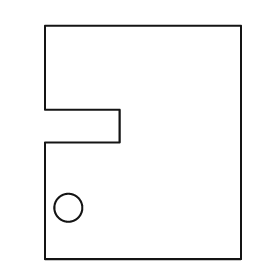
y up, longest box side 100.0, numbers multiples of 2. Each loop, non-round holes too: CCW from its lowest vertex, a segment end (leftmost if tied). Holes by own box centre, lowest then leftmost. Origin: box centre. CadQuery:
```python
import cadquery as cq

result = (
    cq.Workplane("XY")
    .moveTo(-42.0, -50.0)
    .lineTo(42.0, -50.0)
    .lineTo(42.0, 50.0)
    .lineTo(-42.0, 50.0)
    .lineTo(-42.0, 14.0)
    .lineTo(-10.0, 14.0)
    .lineTo(-10.0, 0.0)
    .lineTo(-42.0, 0.0)
    .close()
    .moveTo(-32.0, -28.0)
    .circle(6.0)
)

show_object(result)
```